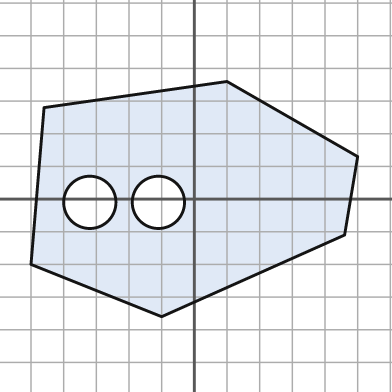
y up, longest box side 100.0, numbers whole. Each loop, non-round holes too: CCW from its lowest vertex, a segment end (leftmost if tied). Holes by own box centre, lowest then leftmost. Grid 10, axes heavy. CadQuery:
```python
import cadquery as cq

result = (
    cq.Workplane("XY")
    .moveTo(-10.0, -36.0)
    .lineTo(46.0, -11.0)
    .lineTo(50.0, 13.0)
    .lineTo(10.0, 36.0)
    .lineTo(-46.0, 28.0)
    .lineTo(-50.0, -20.0)
    .close()
    .moveTo(-32.0, -1.0)
    .circle(8.0)
    .moveTo(-11.0, -1.0)
    .circle(8.0)
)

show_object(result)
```